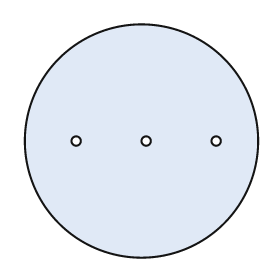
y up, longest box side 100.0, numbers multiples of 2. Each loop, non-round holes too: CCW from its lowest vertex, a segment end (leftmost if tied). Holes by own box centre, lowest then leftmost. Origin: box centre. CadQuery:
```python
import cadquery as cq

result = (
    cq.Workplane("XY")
    .moveTo(0.0, 0.0)
    .circle(50.0)
    .moveTo(-28.0, 0.0)
    .circle(2.0)
    .moveTo(2.0, 0.0)
    .circle(2.0)
    .moveTo(32.0, 0.0)
    .circle(2.0)
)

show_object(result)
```